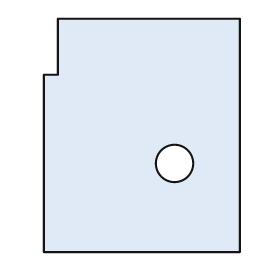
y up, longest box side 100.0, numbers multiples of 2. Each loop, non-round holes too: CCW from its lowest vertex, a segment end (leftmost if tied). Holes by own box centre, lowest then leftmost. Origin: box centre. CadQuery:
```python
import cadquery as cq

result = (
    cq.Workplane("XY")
    .moveTo(-42.0, -50.0)
    .lineTo(42.0, -50.0)
    .lineTo(42.0, 50.0)
    .lineTo(-36.0, 50.0)
    .lineTo(-36.0, 26.0)
    .lineTo(-42.0, 26.0)
    .close()
    .moveTo(14.0, -12.0)
    .circle(8.0)
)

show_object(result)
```